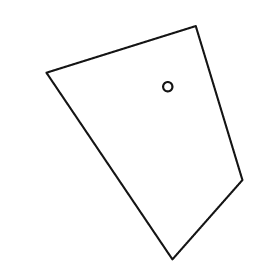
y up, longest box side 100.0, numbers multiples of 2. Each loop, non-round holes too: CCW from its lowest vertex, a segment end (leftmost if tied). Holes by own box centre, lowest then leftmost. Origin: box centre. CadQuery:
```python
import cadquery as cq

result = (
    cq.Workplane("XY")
    .moveTo(12.0, -50.0)
    .lineTo(42.0, -16.0)
    .lineTo(22.0, 50.0)
    .lineTo(-42.0, 30.0)
    .close()
    .moveTo(10.0, 24.0)
    .circle(2.0)
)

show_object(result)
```